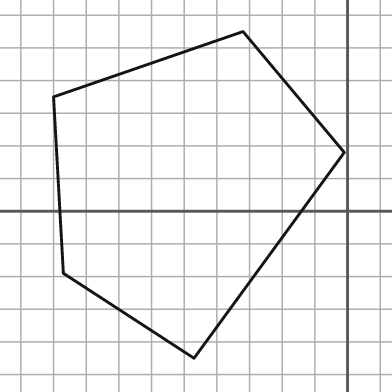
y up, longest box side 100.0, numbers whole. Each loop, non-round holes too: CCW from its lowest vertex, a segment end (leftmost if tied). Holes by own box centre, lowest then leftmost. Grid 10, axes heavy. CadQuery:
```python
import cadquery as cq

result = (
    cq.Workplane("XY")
    .moveTo(-47.0, -45.0)
    .lineTo(-1.0, 18.0)
    .lineTo(-32.0, 55.0)
    .lineTo(-90.0, 35.0)
    .lineTo(-87.0, -19.0)
    .close()
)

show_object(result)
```